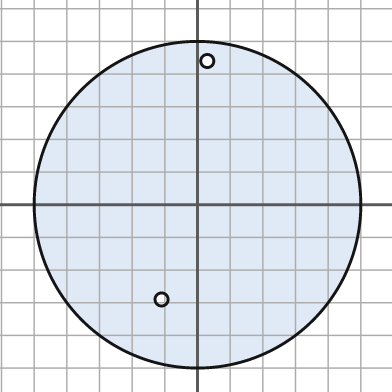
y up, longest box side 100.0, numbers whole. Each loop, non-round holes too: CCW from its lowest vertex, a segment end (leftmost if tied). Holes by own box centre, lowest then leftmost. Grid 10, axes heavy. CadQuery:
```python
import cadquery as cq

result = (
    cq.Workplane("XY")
    .moveTo(0.0, 0.0)
    .circle(50.0)
    .moveTo(-11.0, -29.0)
    .circle(2.0)
    .moveTo(3.0, 44.0)
    .circle(2.0)
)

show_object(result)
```